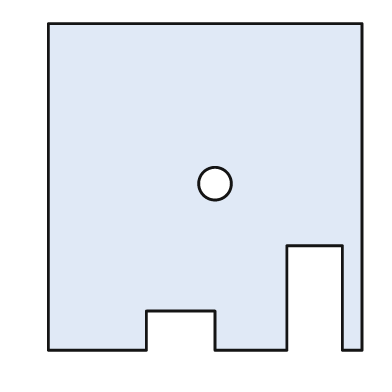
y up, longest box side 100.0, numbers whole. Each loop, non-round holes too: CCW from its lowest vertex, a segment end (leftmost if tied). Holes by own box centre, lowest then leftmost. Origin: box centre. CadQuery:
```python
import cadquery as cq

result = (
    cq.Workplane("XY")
    .moveTo(-48.0, -50.0)
    .lineTo(-18.0, -50.0)
    .lineTo(-18.0, -38.0)
    .lineTo(3.0, -38.0)
    .lineTo(3.0, -50.0)
    .lineTo(25.0, -50.0)
    .lineTo(25.0, -18.0)
    .lineTo(42.0, -18.0)
    .lineTo(42.0, -50.0)
    .lineTo(48.0, -50.0)
    .lineTo(48.0, 50.0)
    .lineTo(-48.0, 50.0)
    .close()
    .moveTo(3.0, 1.0)
    .circle(5.0)
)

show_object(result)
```